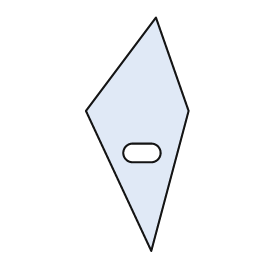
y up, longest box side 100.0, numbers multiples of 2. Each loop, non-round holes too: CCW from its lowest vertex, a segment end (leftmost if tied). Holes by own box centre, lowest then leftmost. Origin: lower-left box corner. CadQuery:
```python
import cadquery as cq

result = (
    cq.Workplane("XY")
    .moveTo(28.0, 0.0)
    .lineTo(44.0, 60.0)
    .lineTo(30.0, 100.0)
    .lineTo(0.0, 60.0)
    .close()
    .moveTo(20.0, 38.0)
    .lineTo(28.0, 38.0)
    .threePointArc((32.0, 42.0), (28.0, 46.0))
    .lineTo(20.0, 46.0)
    .threePointArc((16.0, 42.0), (20.0, 38.0))
    .close()
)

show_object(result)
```